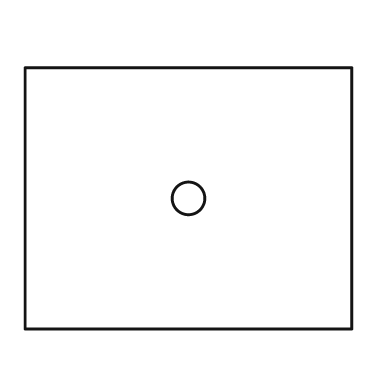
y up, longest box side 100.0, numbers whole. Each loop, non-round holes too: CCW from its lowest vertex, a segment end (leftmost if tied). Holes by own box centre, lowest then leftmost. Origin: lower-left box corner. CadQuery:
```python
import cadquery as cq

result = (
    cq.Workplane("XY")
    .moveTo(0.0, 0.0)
    .lineTo(100.0, 0.0)
    .lineTo(100.0, 80.0)
    .lineTo(0.0, 80.0)
    .close()
    .moveTo(50.0, 40.0)
    .circle(5.0)
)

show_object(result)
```